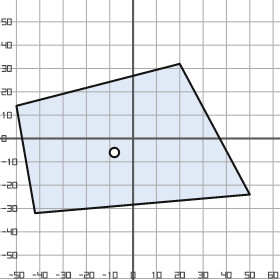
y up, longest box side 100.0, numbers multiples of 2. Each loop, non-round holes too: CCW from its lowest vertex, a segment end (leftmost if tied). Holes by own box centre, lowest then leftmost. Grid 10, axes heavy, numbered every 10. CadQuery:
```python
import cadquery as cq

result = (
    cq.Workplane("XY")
    .moveTo(-42.0, -32.0)
    .lineTo(50.0, -24.0)
    .lineTo(20.0, 32.0)
    .lineTo(-50.0, 14.0)
    .close()
    .moveTo(-8.0, -6.0)
    .circle(2.0)
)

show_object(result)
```